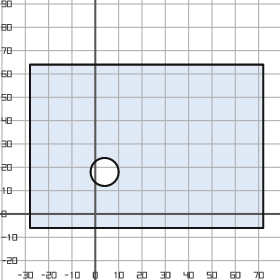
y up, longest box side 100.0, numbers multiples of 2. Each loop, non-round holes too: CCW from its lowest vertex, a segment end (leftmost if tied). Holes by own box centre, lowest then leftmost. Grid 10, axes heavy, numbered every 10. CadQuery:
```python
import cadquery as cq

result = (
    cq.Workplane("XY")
    .moveTo(-28.0, -6.0)
    .lineTo(72.0, -6.0)
    .lineTo(72.0, 64.0)
    .lineTo(-28.0, 64.0)
    .close()
    .moveTo(4.0, 18.0)
    .circle(6.0)
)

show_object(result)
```